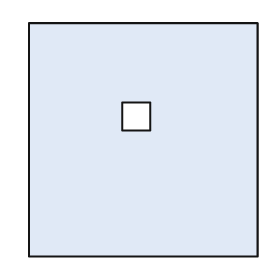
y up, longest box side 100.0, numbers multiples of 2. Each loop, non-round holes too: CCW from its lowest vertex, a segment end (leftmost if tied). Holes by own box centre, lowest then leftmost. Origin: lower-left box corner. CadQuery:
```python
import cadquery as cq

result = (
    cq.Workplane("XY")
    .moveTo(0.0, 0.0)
    .lineTo(98.0, 0.0)
    .lineTo(98.0, 100.0)
    .lineTo(0.0, 100.0)
    .close()
    .moveTo(40.0, 54.0)
    .lineTo(52.0, 54.0)
    .lineTo(52.0, 66.0)
    .lineTo(40.0, 66.0)
    .close()
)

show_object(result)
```